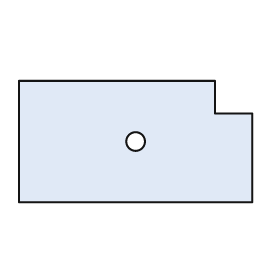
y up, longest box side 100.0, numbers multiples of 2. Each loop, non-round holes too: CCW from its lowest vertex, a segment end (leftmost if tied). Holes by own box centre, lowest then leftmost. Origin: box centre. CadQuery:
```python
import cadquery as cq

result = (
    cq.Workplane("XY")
    .moveTo(-50.0, -26.0)
    .lineTo(50.0, -26.0)
    .lineTo(50.0, 12.0)
    .lineTo(34.0, 12.0)
    .lineTo(34.0, 26.0)
    .lineTo(-50.0, 26.0)
    .close()
    .moveTo(0.0, 0.0)
    .circle(4.0)
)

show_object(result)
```